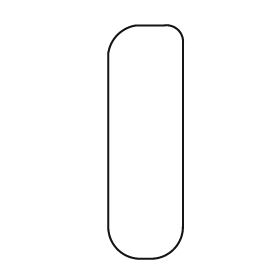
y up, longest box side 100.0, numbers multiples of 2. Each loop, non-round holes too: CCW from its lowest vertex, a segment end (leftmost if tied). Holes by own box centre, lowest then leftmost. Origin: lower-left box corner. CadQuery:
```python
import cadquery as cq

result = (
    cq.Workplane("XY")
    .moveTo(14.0, 0.0)
    .lineTo(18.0, 0.0)
    .threePointArc((28.0, 4.0), (32.0, 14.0))
    .lineTo(32.0, 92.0)
    .threePointArc((30.0, 98.0), (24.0, 100.0))
    .lineTo(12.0, 100.0)
    .threePointArc((4.0, 96.0), (0.0, 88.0))
    .lineTo(0.0, 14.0)
    .threePointArc((4.0, 4.0), (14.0, 0.0))
    .close()
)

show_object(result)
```